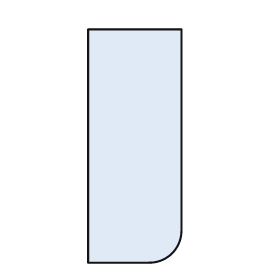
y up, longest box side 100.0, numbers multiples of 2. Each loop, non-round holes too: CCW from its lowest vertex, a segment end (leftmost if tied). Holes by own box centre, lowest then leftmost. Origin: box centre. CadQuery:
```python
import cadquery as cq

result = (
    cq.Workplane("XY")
    .moveTo(-20.0, -50.0)
    .lineTo(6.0, -50.0)
    .threePointArc((16.0, -46.0), (20.0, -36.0))
    .lineTo(20.0, 50.0)
    .lineTo(-20.0, 50.0)
    .close()
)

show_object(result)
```